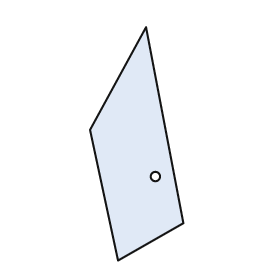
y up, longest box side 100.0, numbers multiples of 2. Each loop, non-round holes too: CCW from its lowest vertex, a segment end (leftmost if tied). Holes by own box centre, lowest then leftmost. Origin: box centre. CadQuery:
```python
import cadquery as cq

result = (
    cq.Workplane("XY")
    .moveTo(-8.0, -50.0)
    .lineTo(20.0, -34.0)
    .lineTo(4.0, 50.0)
    .lineTo(-20.0, 6.0)
    .close()
    .moveTo(8.0, -14.0)
    .circle(2.0)
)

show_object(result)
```